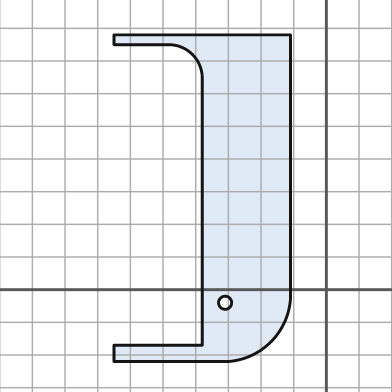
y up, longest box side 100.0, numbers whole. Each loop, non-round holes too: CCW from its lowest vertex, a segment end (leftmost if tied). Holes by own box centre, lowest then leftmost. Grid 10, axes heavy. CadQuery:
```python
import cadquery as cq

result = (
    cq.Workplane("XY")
    .moveTo(-65.0, -22.0)
    .lineTo(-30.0, -22.0)
    .threePointArc((-17.0, -16.0), (-11.0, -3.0))
    .lineTo(-11.0, 78.0)
    .lineTo(-65.0, 78.0)
    .lineTo(-65.0, 75.0)
    .lineTo(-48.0, 75.0)
    .threePointArc((-41.0, 72.0), (-38.0, 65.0))
    .lineTo(-38.0, -17.0)
    .lineTo(-65.0, -17.0)
    .close()
    .moveTo(-31.0, -4.0)
    .circle(2.0)
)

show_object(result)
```